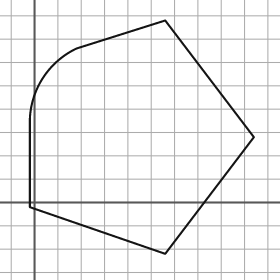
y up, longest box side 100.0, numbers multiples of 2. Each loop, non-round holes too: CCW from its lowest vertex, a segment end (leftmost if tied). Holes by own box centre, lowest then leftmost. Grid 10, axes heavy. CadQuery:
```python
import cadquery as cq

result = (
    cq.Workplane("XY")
    .moveTo(56.0, -22.0)
    .lineTo(94.0, 28.0)
    .lineTo(56.0, 78.0)
    .lineTo(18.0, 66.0)
    .threePointArc((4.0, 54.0), (-2.0, 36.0))
    .lineTo(-2.0, -2.0)
    .close()
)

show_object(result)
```